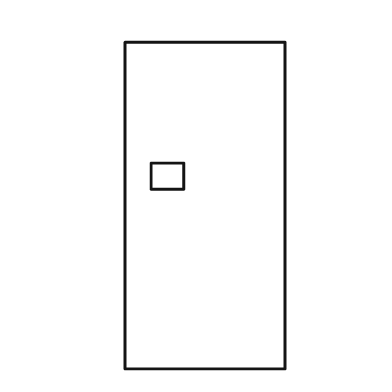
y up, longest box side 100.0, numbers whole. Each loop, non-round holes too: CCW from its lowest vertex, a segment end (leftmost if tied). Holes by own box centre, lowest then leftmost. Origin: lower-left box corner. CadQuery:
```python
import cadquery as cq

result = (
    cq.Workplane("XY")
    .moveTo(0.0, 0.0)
    .lineTo(49.0, 0.0)
    .lineTo(49.0, 100.0)
    .lineTo(0.0, 100.0)
    .close()
    .moveTo(8.0, 55.0)
    .lineTo(18.0, 55.0)
    .lineTo(18.0, 63.0)
    .lineTo(8.0, 63.0)
    .close()
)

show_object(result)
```